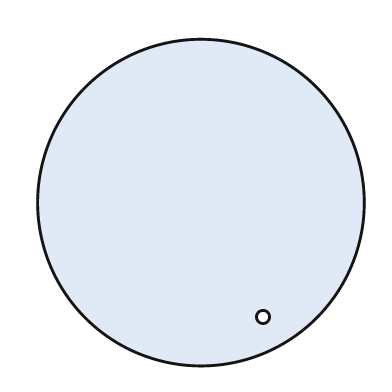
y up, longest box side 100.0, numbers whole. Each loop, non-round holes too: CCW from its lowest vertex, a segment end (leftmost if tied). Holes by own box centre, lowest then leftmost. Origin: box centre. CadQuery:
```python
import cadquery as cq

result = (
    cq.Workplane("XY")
    .moveTo(0.0, 0.0)
    .circle(50.0)
    .moveTo(19.0, -35.0)
    .circle(2.0)
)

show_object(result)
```